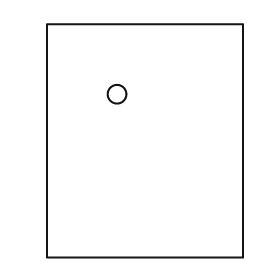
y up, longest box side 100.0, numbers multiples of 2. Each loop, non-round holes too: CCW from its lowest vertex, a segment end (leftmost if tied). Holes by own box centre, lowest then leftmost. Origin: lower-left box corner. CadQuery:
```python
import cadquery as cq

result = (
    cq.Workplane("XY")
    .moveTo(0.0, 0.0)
    .lineTo(84.0, 0.0)
    .lineTo(84.0, 100.0)
    .lineTo(0.0, 100.0)
    .close()
    .moveTo(30.0, 70.0)
    .circle(4.0)
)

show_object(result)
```